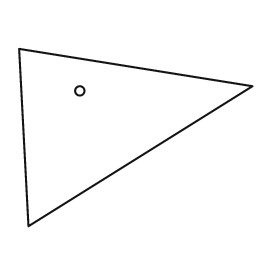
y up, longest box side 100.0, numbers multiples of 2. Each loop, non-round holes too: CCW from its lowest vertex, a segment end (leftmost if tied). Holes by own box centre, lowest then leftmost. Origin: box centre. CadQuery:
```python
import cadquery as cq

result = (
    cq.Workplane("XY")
    .moveTo(-46.0, -38.0)
    .lineTo(50.0, 22.0)
    .lineTo(-50.0, 38.0)
    .close()
    .moveTo(-24.0, 20.0)
    .circle(2.0)
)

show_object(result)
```